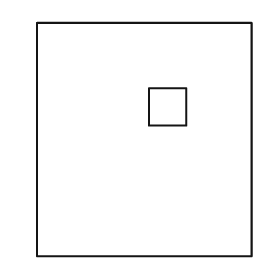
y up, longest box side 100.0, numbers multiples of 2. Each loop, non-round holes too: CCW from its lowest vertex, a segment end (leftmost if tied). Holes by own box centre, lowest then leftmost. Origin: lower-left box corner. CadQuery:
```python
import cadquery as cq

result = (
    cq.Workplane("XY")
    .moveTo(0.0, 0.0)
    .lineTo(92.0, 0.0)
    .lineTo(92.0, 100.0)
    .lineTo(0.0, 100.0)
    .close()
    .moveTo(48.0, 56.0)
    .lineTo(64.0, 56.0)
    .lineTo(64.0, 72.0)
    .lineTo(48.0, 72.0)
    .close()
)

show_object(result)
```